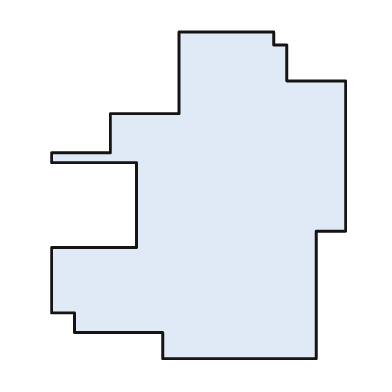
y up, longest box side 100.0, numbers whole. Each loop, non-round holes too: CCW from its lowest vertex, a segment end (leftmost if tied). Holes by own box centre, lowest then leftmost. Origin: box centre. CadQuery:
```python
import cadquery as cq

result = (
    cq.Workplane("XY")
    .moveTo(-11.0, -50.0)
    .lineTo(36.0, -50.0)
    .lineTo(36.0, -11.0)
    .lineTo(45.0, -11.0)
    .lineTo(45.0, 35.0)
    .lineTo(27.0, 35.0)
    .lineTo(27.0, 46.0)
    .lineTo(23.0, 46.0)
    .lineTo(23.0, 50.0)
    .lineTo(-6.0, 50.0)
    .lineTo(-6.0, 25.0)
    .lineTo(-27.0, 25.0)
    .lineTo(-27.0, 13.0)
    .lineTo(-45.0, 13.0)
    .lineTo(-45.0, 10.0)
    .lineTo(-19.0, 10.0)
    .lineTo(-19.0, -16.0)
    .lineTo(-45.0, -16.0)
    .lineTo(-45.0, -36.0)
    .lineTo(-38.0, -36.0)
    .lineTo(-38.0, -42.0)
    .lineTo(-11.0, -42.0)
    .close()
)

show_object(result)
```